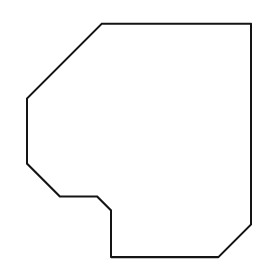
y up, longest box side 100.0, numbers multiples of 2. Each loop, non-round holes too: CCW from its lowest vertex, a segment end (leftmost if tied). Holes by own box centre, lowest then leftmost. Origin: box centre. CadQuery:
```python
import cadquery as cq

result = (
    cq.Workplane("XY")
    .moveTo(-12.0, -50.0)
    .lineTo(34.0, -50.0)
    .lineTo(48.0, -36.0)
    .lineTo(48.0, 50.0)
    .lineTo(-16.0, 50.0)
    .lineTo(-48.0, 18.0)
    .lineTo(-48.0, -10.0)
    .lineTo(-34.0, -24.0)
    .lineTo(-18.0, -24.0)
    .lineTo(-12.0, -30.0)
    .close()
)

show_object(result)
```